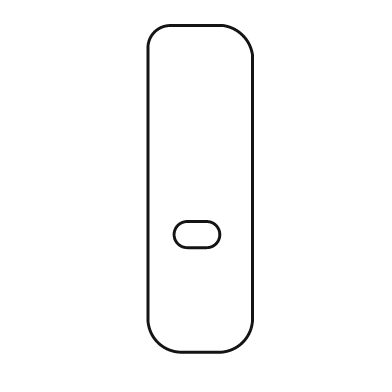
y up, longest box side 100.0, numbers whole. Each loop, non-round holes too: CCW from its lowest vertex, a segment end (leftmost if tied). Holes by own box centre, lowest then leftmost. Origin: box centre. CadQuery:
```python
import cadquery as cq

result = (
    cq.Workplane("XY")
    .moveTo(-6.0, -50.0)
    .lineTo(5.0, -50.0)
    .threePointArc((13.0, -47.0), (16.0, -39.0))
    .lineTo(16.0, 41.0)
    .threePointArc((13.0, 47.0), (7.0, 50.0))
    .lineTo(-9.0, 50.0)
    .threePointArc((-14.0, 48.0), (-16.0, 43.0))
    .lineTo(-16.0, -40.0)
    .threePointArc((-13.0, -47.0), (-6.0, -50.0))
    .close()
    .moveTo(-4.0, -18.0)
    .lineTo(2.0, -18.0)
    .threePointArc((6.0, -14.0), (2.0, -10.0))
    .lineTo(-4.0, -10.0)
    .threePointArc((-8.0, -14.0), (-4.0, -18.0))
    .close()
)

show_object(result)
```